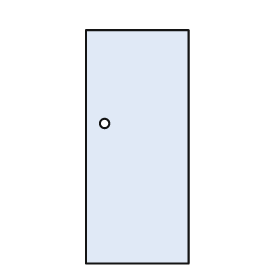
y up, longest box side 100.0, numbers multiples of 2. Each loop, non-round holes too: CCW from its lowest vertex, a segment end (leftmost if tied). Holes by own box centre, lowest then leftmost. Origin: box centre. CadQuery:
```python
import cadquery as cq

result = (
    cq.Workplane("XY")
    .moveTo(-22.0, -50.0)
    .lineTo(22.0, -50.0)
    .lineTo(22.0, 50.0)
    .lineTo(-22.0, 50.0)
    .close()
    .moveTo(-14.0, 10.0)
    .circle(2.0)
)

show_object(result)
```